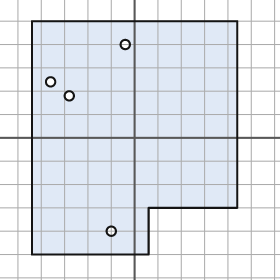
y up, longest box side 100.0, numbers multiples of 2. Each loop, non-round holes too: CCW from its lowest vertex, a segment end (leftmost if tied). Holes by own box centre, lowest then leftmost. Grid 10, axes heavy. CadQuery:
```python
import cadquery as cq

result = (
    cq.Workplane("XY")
    .moveTo(-44.0, -50.0)
    .lineTo(6.0, -50.0)
    .lineTo(6.0, -30.0)
    .lineTo(44.0, -30.0)
    .lineTo(44.0, 50.0)
    .lineTo(-44.0, 50.0)
    .close()
    .moveTo(-10.0, -40.0)
    .circle(2.0)
    .moveTo(-28.0, 18.0)
    .circle(2.0)
    .moveTo(-36.0, 24.0)
    .circle(2.0)
    .moveTo(-4.0, 40.0)
    .circle(2.0)
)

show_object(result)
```